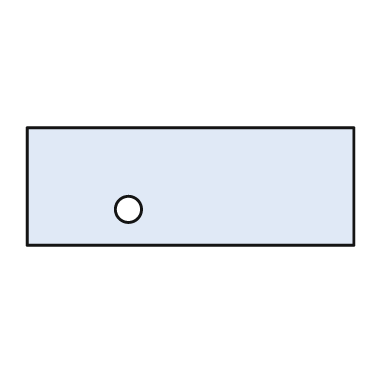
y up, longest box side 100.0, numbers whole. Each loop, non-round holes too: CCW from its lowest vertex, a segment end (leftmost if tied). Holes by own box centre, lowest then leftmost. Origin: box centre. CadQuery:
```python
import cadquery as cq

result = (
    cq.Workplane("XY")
    .moveTo(-50.0, -18.0)
    .lineTo(50.0, -18.0)
    .lineTo(50.0, 18.0)
    .lineTo(-50.0, 18.0)
    .close()
    .moveTo(-19.0, -7.0)
    .circle(4.0)
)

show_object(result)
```